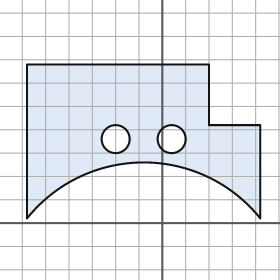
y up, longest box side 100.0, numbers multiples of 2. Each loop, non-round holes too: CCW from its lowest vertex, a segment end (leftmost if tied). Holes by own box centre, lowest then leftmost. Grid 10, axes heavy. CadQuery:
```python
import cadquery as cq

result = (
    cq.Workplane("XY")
    .moveTo(-58.0, 2.0)
    .threePointArc((-8.0, 26.0), (42.0, 2.0))
    .lineTo(42.0, 42.0)
    .lineTo(20.0, 42.0)
    .lineTo(20.0, 68.0)
    .lineTo(-58.0, 68.0)
    .close()
    .moveTo(-20.0, 36.0)
    .circle(6.0)
    .moveTo(4.0, 36.0)
    .circle(6.0)
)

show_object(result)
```